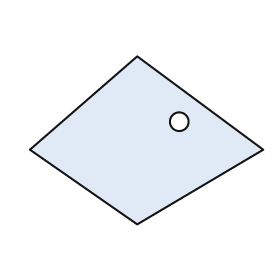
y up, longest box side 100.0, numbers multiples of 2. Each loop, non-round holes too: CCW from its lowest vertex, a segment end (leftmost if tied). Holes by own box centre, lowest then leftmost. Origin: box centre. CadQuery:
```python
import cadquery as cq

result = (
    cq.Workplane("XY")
    .moveTo(-4.0, -36.0)
    .lineTo(50.0, -4.0)
    .lineTo(-4.0, 36.0)
    .lineTo(-50.0, -4.0)
    .close()
    .moveTo(14.0, 8.0)
    .circle(4.0)
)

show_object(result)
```